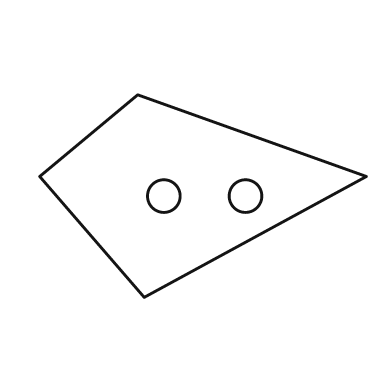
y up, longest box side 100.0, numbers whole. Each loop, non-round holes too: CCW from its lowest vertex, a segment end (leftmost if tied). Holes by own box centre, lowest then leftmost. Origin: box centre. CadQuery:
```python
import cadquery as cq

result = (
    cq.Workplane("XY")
    .moveTo(-18.0, -31.0)
    .lineTo(50.0, 6.0)
    .lineTo(-20.0, 31.0)
    .lineTo(-50.0, 6.0)
    .close()
    .moveTo(-12.0, 0.0)
    .circle(5.0)
    .moveTo(13.0, 0.0)
    .circle(5.0)
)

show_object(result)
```